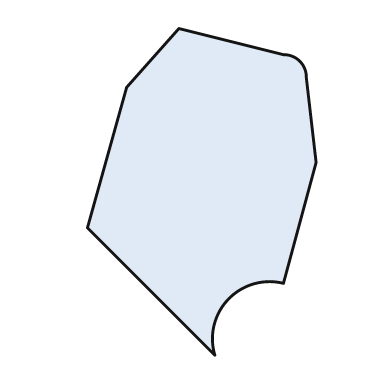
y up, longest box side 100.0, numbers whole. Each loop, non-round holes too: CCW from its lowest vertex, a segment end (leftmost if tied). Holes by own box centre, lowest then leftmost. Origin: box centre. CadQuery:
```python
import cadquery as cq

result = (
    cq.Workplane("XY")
    .moveTo(4.0, -50.0)
    .threePointArc((8.0, -33.0), (25.0, -28.0))
    .lineTo(35.0, 9.0)
    .lineTo(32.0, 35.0)
    .threePointArc((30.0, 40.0), (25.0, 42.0))
    .lineTo(-7.0, 50.0)
    .lineTo(-23.0, 32.0)
    .lineTo(-35.0, -11.0)
    .close()
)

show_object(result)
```